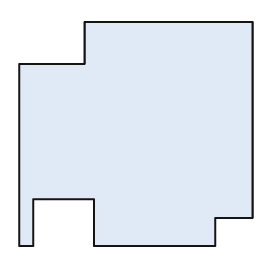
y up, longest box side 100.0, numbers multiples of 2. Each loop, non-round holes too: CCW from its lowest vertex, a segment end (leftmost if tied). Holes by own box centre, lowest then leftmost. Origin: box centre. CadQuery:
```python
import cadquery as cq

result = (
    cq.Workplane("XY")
    .moveTo(-50.0, -48.0)
    .lineTo(-44.0, -48.0)
    .lineTo(-44.0, -28.0)
    .lineTo(-18.0, -28.0)
    .lineTo(-18.0, -48.0)
    .lineTo(34.0, -48.0)
    .lineTo(34.0, -36.0)
    .lineTo(50.0, -36.0)
    .lineTo(50.0, 48.0)
    .lineTo(-22.0, 48.0)
    .lineTo(-22.0, 30.0)
    .lineTo(-50.0, 30.0)
    .close()
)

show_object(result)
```